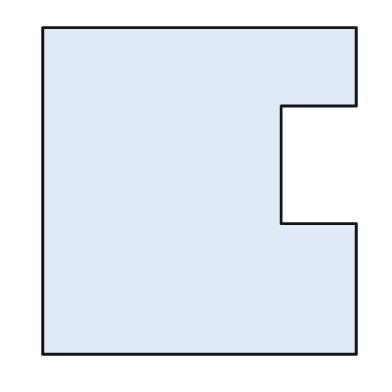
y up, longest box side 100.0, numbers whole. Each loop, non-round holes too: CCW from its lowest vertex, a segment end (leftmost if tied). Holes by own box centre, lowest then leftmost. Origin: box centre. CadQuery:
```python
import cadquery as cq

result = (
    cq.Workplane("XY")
    .moveTo(-48.0, -50.0)
    .lineTo(48.0, -50.0)
    .lineTo(48.0, -10.0)
    .lineTo(25.0, -10.0)
    .lineTo(25.0, 26.0)
    .lineTo(48.0, 26.0)
    .lineTo(48.0, 50.0)
    .lineTo(-48.0, 50.0)
    .close()
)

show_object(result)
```